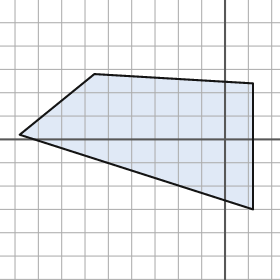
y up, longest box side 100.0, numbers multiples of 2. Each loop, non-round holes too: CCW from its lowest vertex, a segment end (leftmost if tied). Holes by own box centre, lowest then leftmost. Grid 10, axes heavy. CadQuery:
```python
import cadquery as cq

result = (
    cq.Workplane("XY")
    .moveTo(12.0, -30.0)
    .lineTo(12.0, 24.0)
    .lineTo(-56.0, 28.0)
    .lineTo(-88.0, 2.0)
    .close()
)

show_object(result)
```